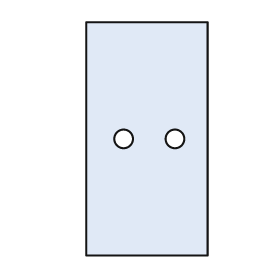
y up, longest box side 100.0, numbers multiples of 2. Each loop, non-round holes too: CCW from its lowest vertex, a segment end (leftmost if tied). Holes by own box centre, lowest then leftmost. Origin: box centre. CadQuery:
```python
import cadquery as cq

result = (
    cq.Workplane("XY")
    .moveTo(-26.0, -50.0)
    .lineTo(26.0, -50.0)
    .lineTo(26.0, 50.0)
    .lineTo(-26.0, 50.0)
    .close()
    .moveTo(-10.0, 0.0)
    .circle(4.0)
    .moveTo(12.0, 0.0)
    .circle(4.0)
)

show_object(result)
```